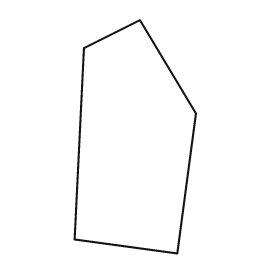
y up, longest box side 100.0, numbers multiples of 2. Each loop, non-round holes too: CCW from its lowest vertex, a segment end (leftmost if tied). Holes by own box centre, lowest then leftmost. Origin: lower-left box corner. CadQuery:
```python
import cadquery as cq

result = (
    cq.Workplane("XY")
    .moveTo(44.0, 0.0)
    .lineTo(52.0, 60.0)
    .lineTo(28.0, 100.0)
    .lineTo(4.0, 88.0)
    .lineTo(0.0, 6.0)
    .close()
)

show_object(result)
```